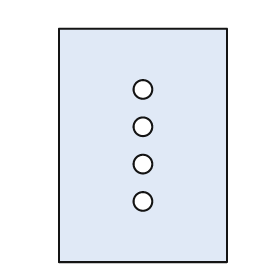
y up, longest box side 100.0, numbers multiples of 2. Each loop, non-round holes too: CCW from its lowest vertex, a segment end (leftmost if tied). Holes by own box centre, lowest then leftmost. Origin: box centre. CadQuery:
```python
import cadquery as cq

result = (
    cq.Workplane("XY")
    .moveTo(-36.0, -50.0)
    .lineTo(36.0, -50.0)
    .lineTo(36.0, 50.0)
    .lineTo(-36.0, 50.0)
    .close()
    .moveTo(0.0, -24.0)
    .circle(4.0)
    .moveTo(0.0, -8.0)
    .circle(4.0)
    .moveTo(0.0, 8.0)
    .circle(4.0)
    .moveTo(0.0, 24.0)
    .circle(4.0)
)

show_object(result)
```